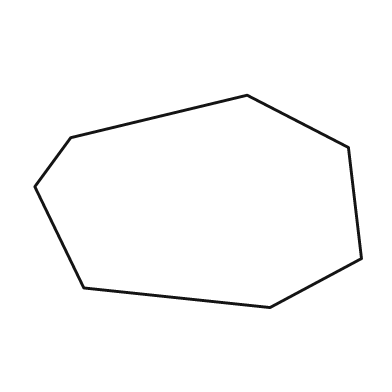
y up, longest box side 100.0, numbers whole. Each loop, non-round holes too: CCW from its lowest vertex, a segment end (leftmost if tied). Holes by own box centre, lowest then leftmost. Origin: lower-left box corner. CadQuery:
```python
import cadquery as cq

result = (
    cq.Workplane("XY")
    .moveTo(72.0, 0.0)
    .lineTo(100.0, 15.0)
    .lineTo(96.0, 49.0)
    .lineTo(65.0, 65.0)
    .lineTo(11.0, 52.0)
    .lineTo(0.0, 37.0)
    .lineTo(15.0, 6.0)
    .close()
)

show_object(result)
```